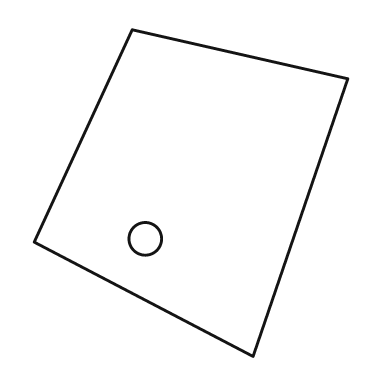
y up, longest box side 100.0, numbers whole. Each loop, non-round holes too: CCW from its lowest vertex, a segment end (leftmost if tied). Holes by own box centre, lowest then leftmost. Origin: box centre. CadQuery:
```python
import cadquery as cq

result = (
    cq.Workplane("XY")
    .moveTo(19.0, -50.0)
    .lineTo(48.0, 35.0)
    .lineTo(-18.0, 50.0)
    .lineTo(-48.0, -15.0)
    .close()
    .moveTo(-14.0, -14.0)
    .circle(5.0)
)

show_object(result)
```